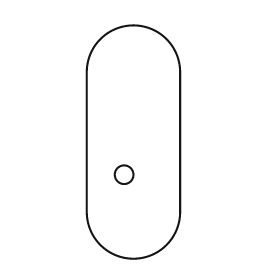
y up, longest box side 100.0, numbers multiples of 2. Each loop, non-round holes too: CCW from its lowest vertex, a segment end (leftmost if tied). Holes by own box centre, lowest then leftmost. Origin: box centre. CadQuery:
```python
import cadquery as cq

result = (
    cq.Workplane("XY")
    .moveTo(-20.0, -30.0)
    .threePointArc((0.0, -50.0), (20.0, -30.0))
    .lineTo(20.0, 30.0)
    .threePointArc((0.0, 50.0), (-20.0, 30.0))
    .close()
    .moveTo(-4.0, -14.0)
    .circle(4.0)
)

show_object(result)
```